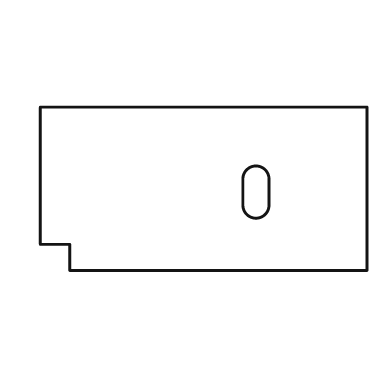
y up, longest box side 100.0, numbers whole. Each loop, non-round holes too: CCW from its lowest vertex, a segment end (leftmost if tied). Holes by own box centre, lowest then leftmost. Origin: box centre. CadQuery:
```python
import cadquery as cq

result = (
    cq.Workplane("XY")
    .moveTo(-41.0, -25.0)
    .lineTo(50.0, -25.0)
    .lineTo(50.0, 25.0)
    .lineTo(-50.0, 25.0)
    .lineTo(-50.0, -17.0)
    .lineTo(-41.0, -17.0)
    .close()
    .moveTo(12.0, -5.0)
    .threePointArc((16.0, -9.0), (20.0, -5.0))
    .lineTo(20.0, 3.0)
    .threePointArc((16.0, 7.0), (12.0, 3.0))
    .close()
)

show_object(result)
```